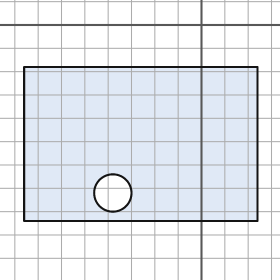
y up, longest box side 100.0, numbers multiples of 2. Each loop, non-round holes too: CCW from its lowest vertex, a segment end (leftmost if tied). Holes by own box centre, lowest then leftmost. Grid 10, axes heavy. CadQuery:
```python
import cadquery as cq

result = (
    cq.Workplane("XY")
    .moveTo(-76.0, -84.0)
    .lineTo(24.0, -84.0)
    .lineTo(24.0, -18.0)
    .lineTo(-76.0, -18.0)
    .close()
    .moveTo(-38.0, -72.0)
    .circle(8.0)
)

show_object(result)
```